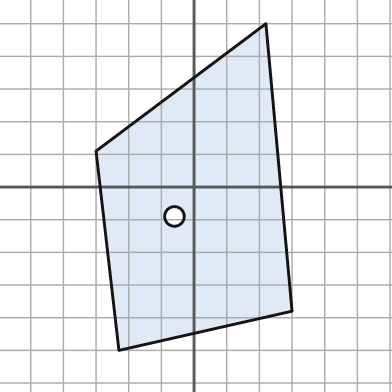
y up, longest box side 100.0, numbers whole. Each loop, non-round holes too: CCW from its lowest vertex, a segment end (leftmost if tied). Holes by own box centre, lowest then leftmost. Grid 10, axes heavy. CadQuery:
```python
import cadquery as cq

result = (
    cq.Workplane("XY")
    .moveTo(-23.0, -50.0)
    .lineTo(30.0, -38.0)
    .lineTo(22.0, 50.0)
    .lineTo(-30.0, 11.0)
    .close()
    .moveTo(-6.0, -9.0)
    .circle(3.0)
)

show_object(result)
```